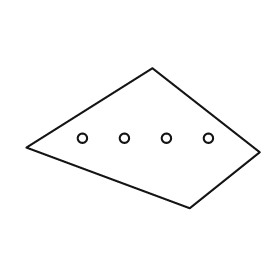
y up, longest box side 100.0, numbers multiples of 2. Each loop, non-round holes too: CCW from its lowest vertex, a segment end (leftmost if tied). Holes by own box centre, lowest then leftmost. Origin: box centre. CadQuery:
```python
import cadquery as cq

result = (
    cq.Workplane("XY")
    .moveTo(20.0, -30.0)
    .lineTo(50.0, -6.0)
    .lineTo(4.0, 30.0)
    .lineTo(-50.0, -4.0)
    .close()
    .moveTo(-26.0, 0.0)
    .circle(2.0)
    .moveTo(-8.0, 0.0)
    .circle(2.0)
    .moveTo(10.0, 0.0)
    .circle(2.0)
    .moveTo(28.0, 0.0)
    .circle(2.0)
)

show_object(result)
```